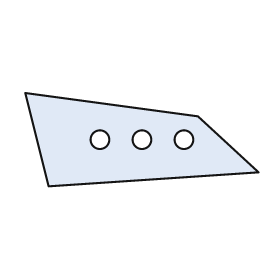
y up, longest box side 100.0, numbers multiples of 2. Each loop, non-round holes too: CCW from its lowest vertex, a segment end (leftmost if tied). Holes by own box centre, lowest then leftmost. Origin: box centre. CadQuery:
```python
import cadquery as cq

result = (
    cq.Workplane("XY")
    .moveTo(-40.0, -20.0)
    .lineTo(50.0, -14.0)
    .lineTo(24.0, 10.0)
    .lineTo(-50.0, 20.0)
    .close()
    .moveTo(-18.0, 0.0)
    .circle(4.0)
    .moveTo(0.0, 0.0)
    .circle(4.0)
    .moveTo(18.0, 0.0)
    .circle(4.0)
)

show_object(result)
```